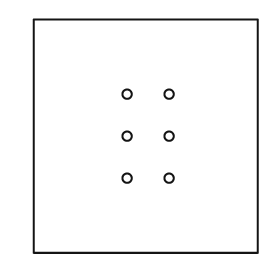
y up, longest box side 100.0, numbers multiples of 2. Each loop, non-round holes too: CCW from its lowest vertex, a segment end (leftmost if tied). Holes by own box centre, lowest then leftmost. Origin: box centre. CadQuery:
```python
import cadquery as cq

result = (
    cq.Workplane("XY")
    .moveTo(-48.0, -50.0)
    .lineTo(48.0, -50.0)
    .lineTo(48.0, 50.0)
    .lineTo(-48.0, 50.0)
    .close()
    .moveTo(-8.0, -18.0)
    .circle(2.0)
    .moveTo(10.0, -18.0)
    .circle(2.0)
    .moveTo(-8.0, 0.0)
    .circle(2.0)
    .moveTo(10.0, 0.0)
    .circle(2.0)
    .moveTo(-8.0, 18.0)
    .circle(2.0)
    .moveTo(10.0, 18.0)
    .circle(2.0)
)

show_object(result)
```